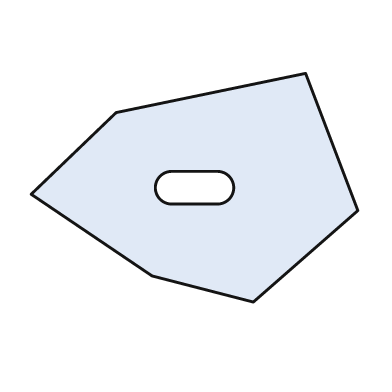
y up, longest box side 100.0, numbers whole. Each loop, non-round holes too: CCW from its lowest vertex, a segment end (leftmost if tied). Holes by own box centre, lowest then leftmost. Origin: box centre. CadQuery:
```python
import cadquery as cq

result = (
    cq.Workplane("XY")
    .moveTo(18.0, -35.0)
    .lineTo(50.0, -7.0)
    .lineTo(34.0, 35.0)
    .lineTo(-24.0, 23.0)
    .lineTo(-50.0, -2.0)
    .lineTo(-13.0, -27.0)
    .close()
    .moveTo(-7.0, -5.0)
    .lineTo(7.0, -5.0)
    .threePointArc((12.0, 0.0), (7.0, 5.0))
    .lineTo(-7.0, 5.0)
    .threePointArc((-12.0, 0.0), (-7.0, -5.0))
    .close()
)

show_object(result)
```